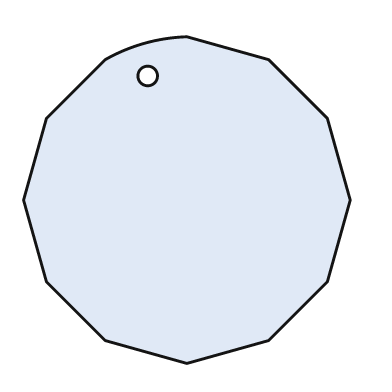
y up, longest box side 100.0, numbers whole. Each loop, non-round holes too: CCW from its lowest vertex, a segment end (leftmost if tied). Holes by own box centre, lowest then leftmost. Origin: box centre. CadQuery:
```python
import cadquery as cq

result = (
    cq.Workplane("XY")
    .moveTo(0.0, -50.0)
    .lineTo(25.0, -43.0)
    .lineTo(43.0, -25.0)
    .lineTo(50.0, 0.0)
    .lineTo(43.0, 25.0)
    .lineTo(25.0, 43.0)
    .lineTo(0.0, 50.0)
    .threePointArc((-13.0, 48.0), (-25.0, 43.0))
    .lineTo(-43.0, 25.0)
    .lineTo(-50.0, 0.0)
    .lineTo(-43.0, -25.0)
    .lineTo(-25.0, -43.0)
    .close()
    .moveTo(-12.0, 38.0)
    .circle(3.0)
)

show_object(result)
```